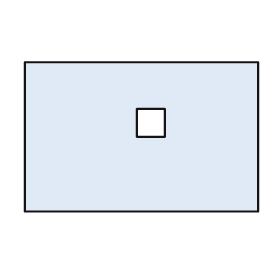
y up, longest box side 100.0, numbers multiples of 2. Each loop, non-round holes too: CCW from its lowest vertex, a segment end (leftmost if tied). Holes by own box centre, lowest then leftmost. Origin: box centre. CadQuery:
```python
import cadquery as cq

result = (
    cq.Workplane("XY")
    .moveTo(-50.0, -32.0)
    .lineTo(50.0, -32.0)
    .lineTo(50.0, 32.0)
    .lineTo(-50.0, 32.0)
    .close()
    .moveTo(-2.0, 0.0)
    .lineTo(10.0, 0.0)
    .lineTo(10.0, 12.0)
    .lineTo(-2.0, 12.0)
    .close()
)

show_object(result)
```